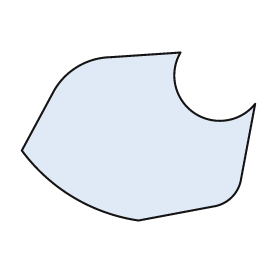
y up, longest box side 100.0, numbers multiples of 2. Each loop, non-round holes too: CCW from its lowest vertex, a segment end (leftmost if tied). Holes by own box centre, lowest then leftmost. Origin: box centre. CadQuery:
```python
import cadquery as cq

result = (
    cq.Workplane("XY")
    .moveTo(0.0, -36.0)
    .lineTo(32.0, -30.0)
    .threePointArc((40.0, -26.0), (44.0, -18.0))
    .lineTo(50.0, 14.0)
    .threePointArc((24.0, 10.0), (18.0, 36.0))
    .lineTo(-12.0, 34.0)
    .threePointArc((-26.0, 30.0), (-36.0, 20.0))
    .lineTo(-50.0, -6.0)
    .threePointArc((-28.0, -26.0), (0.0, -36.0))
    .close()
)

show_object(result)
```